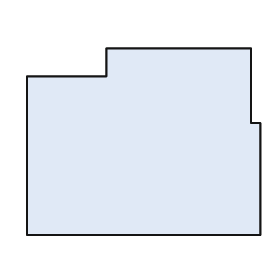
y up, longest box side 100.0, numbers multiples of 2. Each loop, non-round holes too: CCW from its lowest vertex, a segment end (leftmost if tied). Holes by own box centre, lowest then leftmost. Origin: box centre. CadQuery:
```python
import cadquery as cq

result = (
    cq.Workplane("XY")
    .moveTo(-50.0, -40.0)
    .lineTo(50.0, -40.0)
    .lineTo(50.0, 8.0)
    .lineTo(46.0, 8.0)
    .lineTo(46.0, 40.0)
    .lineTo(-16.0, 40.0)
    .lineTo(-16.0, 28.0)
    .lineTo(-50.0, 28.0)
    .close()
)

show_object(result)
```